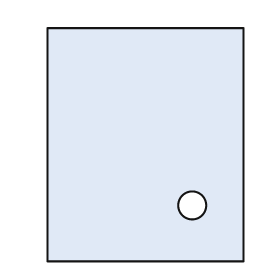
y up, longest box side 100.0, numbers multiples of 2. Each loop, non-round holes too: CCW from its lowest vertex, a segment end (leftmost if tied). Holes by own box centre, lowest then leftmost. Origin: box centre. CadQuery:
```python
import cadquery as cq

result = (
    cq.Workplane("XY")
    .moveTo(-42.0, -50.0)
    .lineTo(42.0, -50.0)
    .lineTo(42.0, 50.0)
    .lineTo(-42.0, 50.0)
    .close()
    .moveTo(20.0, -26.0)
    .circle(6.0)
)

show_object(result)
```